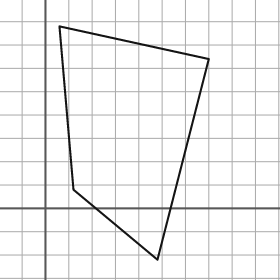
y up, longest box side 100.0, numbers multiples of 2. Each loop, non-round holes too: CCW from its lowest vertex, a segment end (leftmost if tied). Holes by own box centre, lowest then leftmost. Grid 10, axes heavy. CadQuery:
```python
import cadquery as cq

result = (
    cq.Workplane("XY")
    .moveTo(48.0, -22.0)
    .lineTo(70.0, 64.0)
    .lineTo(6.0, 78.0)
    .lineTo(12.0, 8.0)
    .close()
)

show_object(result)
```